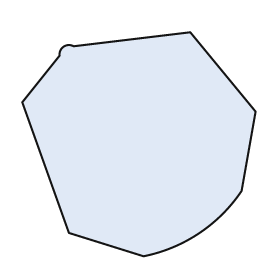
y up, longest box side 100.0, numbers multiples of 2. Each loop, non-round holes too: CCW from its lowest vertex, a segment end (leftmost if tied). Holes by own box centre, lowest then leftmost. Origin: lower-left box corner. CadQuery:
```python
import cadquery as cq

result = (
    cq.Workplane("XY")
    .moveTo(52.0, 0.0)
    .threePointArc((76.0, 10.0), (94.0, 28.0))
    .lineTo(100.0, 62.0)
    .lineTo(72.0, 96.0)
    .lineTo(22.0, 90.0)
    .threePointArc((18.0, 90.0), (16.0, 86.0))
    .lineTo(0.0, 66.0)
    .lineTo(20.0, 10.0)
    .close()
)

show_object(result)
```